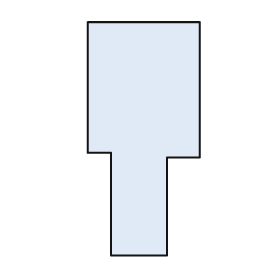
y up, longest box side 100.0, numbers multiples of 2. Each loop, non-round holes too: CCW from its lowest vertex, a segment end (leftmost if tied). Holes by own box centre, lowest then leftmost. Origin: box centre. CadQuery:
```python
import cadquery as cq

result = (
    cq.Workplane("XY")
    .moveTo(-14.0, -50.0)
    .lineTo(10.0, -50.0)
    .lineTo(10.0, -8.0)
    .lineTo(24.0, -8.0)
    .lineTo(24.0, 50.0)
    .lineTo(-24.0, 50.0)
    .lineTo(-24.0, -6.0)
    .lineTo(-14.0, -6.0)
    .close()
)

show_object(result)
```